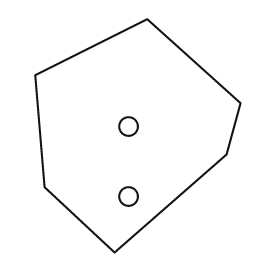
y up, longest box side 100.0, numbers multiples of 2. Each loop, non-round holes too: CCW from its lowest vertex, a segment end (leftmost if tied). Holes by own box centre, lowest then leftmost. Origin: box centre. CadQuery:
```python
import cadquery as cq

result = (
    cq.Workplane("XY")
    .moveTo(-10.0, -50.0)
    .lineTo(38.0, -8.0)
    .lineTo(44.0, 14.0)
    .lineTo(4.0, 50.0)
    .lineTo(-44.0, 26.0)
    .lineTo(-40.0, -22.0)
    .close()
    .moveTo(-4.0, -26.0)
    .circle(4.0)
    .moveTo(-4.0, 4.0)
    .circle(4.0)
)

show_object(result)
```